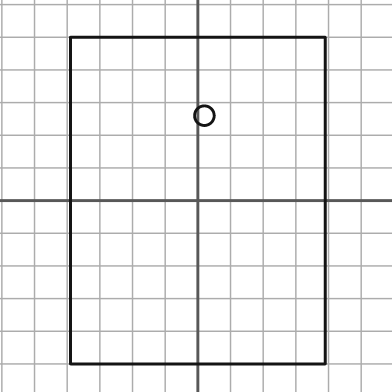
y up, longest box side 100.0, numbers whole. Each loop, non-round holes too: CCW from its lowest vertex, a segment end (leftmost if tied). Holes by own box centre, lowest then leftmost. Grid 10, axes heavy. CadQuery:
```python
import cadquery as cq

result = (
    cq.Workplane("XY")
    .moveTo(-39.0, -50.0)
    .lineTo(39.0, -50.0)
    .lineTo(39.0, 50.0)
    .lineTo(-39.0, 50.0)
    .close()
    .moveTo(2.0, 26.0)
    .circle(3.0)
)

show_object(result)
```